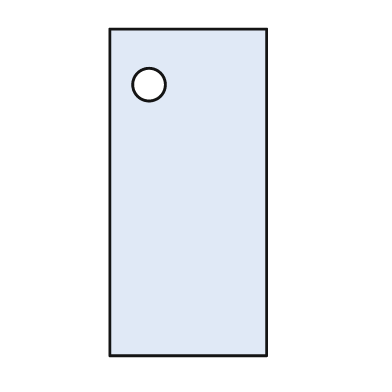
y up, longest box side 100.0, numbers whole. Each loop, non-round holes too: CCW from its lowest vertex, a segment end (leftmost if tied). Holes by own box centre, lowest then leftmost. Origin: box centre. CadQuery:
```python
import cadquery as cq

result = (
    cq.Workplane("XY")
    .moveTo(-24.0, -50.0)
    .lineTo(24.0, -50.0)
    .lineTo(24.0, 50.0)
    .lineTo(-24.0, 50.0)
    .close()
    .moveTo(-12.0, 33.0)
    .circle(5.0)
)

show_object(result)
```